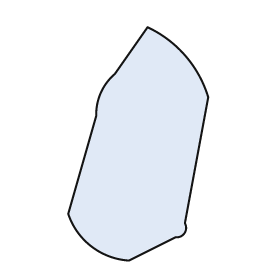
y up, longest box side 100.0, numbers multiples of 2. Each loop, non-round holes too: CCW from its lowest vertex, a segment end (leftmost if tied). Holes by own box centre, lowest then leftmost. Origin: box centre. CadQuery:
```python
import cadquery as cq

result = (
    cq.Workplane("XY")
    .moveTo(-4.0, -50.0)
    .lineTo(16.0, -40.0)
    .threePointArc((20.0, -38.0), (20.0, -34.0))
    .lineTo(30.0, 20.0)
    .threePointArc((20.0, 38.0), (4.0, 50.0))
    .lineTo(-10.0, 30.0)
    .threePointArc((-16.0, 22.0), (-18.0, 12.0))
    .lineTo(-30.0, -30.0)
    .threePointArc((-20.0, -44.0), (-4.0, -50.0))
    .close()
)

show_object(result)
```